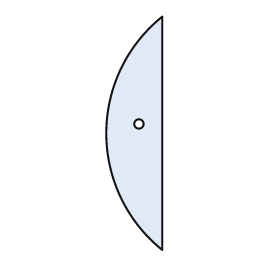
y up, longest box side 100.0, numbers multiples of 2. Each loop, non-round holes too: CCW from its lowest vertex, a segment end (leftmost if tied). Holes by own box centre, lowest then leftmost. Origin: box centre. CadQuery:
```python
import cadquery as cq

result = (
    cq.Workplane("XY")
    .moveTo(12.0, -50.0)
    .lineTo(12.0, 50.0)
    .threePointArc((-12.0, 0.0), (12.0, -50.0))
    .close()
    .moveTo(2.0, 4.0)
    .circle(2.0)
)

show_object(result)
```